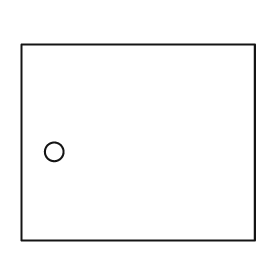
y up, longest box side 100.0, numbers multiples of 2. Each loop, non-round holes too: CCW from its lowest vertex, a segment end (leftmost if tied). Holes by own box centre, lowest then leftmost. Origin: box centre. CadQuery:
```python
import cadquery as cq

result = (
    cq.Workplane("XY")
    .moveTo(-50.0, -42.0)
    .lineTo(50.0, -42.0)
    .lineTo(50.0, 42.0)
    .lineTo(-50.0, 42.0)
    .close()
    .moveTo(-36.0, -4.0)
    .circle(4.0)
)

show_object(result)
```